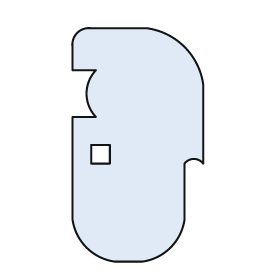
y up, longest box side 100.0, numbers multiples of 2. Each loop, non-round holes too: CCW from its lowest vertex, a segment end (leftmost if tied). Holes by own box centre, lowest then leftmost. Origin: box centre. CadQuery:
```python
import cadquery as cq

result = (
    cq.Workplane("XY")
    .moveTo(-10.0, -50.0)
    .lineTo(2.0, -50.0)
    .threePointArc((14.0, -44.0), (20.0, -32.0))
    .lineTo(20.0, -8.0)
    .threePointArc((24.0, -6.0), (28.0, -8.0))
    .lineTo(28.0, 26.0)
    .threePointArc((20.0, 42.0), (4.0, 50.0))
    .lineTo(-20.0, 50.0)
    .threePointArc((-26.0, 48.0), (-28.0, 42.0))
    .lineTo(-28.0, 32.0)
    .lineTo(-18.0, 32.0)
    .threePointArc((-22.0, 22.0), (-18.0, 12.0))
    .lineTo(-28.0, 12.0)
    .lineTo(-28.0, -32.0)
    .threePointArc((-22.0, -44.0), (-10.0, -50.0))
    .close()
    .moveTo(-20.0, -8.0)
    .lineTo(-12.0, -8.0)
    .lineTo(-12.0, 0.0)
    .lineTo(-20.0, 0.0)
    .close()
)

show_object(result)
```